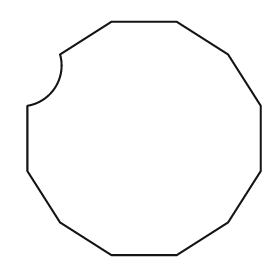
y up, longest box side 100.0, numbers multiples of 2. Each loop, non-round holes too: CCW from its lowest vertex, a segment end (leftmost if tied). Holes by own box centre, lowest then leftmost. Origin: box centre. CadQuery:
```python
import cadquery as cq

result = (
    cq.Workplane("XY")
    .moveTo(-14.0, -50.0)
    .lineTo(14.0, -50.0)
    .lineTo(36.0, -36.0)
    .lineTo(50.0, -14.0)
    .lineTo(50.0, 14.0)
    .lineTo(36.0, 36.0)
    .lineTo(14.0, 50.0)
    .lineTo(-14.0, 50.0)
    .lineTo(-36.0, 36.0)
    .threePointArc((-38.0, 22.0), (-50.0, 14.0))
    .lineTo(-50.0, -14.0)
    .lineTo(-36.0, -36.0)
    .close()
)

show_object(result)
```